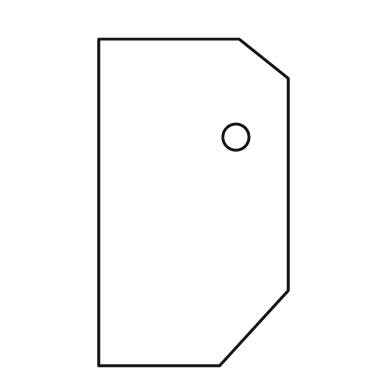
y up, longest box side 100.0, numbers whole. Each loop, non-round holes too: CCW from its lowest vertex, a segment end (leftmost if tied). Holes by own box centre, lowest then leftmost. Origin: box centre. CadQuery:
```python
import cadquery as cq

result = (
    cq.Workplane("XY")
    .moveTo(-29.0, -50.0)
    .lineTo(8.0, -50.0)
    .lineTo(29.0, -27.0)
    .lineTo(29.0, 38.0)
    .lineTo(14.0, 50.0)
    .lineTo(-29.0, 50.0)
    .close()
    .moveTo(13.0, 20.0)
    .circle(4.0)
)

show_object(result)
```